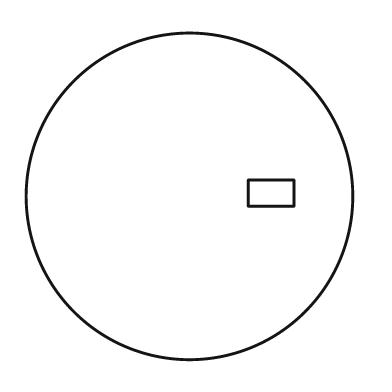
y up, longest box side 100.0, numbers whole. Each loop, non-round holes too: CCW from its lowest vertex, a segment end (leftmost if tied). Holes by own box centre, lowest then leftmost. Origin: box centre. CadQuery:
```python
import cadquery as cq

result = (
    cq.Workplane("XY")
    .moveTo(0.0, 0.0)
    .circle(50.0)
    .moveTo(18.0, -3.0)
    .lineTo(32.0, -3.0)
    .lineTo(32.0, 5.0)
    .lineTo(18.0, 5.0)
    .close()
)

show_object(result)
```